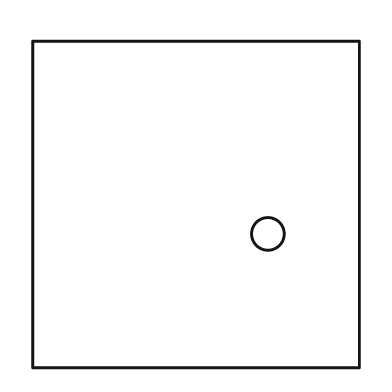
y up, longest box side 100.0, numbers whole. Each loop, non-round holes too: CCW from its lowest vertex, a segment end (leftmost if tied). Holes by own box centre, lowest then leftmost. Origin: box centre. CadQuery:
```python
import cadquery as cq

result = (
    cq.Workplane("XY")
    .moveTo(-50.0, -50.0)
    .lineTo(50.0, -50.0)
    .lineTo(50.0, 50.0)
    .lineTo(-50.0, 50.0)
    .close()
    .moveTo(22.0, -9.0)
    .circle(5.0)
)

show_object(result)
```